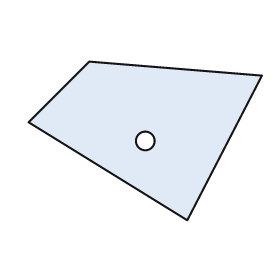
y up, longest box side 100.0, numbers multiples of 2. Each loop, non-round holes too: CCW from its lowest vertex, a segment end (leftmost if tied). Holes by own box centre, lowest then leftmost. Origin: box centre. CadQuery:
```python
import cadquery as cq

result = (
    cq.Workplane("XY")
    .moveTo(18.0, -34.0)
    .lineTo(50.0, 28.0)
    .lineTo(-24.0, 34.0)
    .lineTo(-50.0, 8.0)
    .close()
    .moveTo(0.0, 0.0)
    .circle(4.0)
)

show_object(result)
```